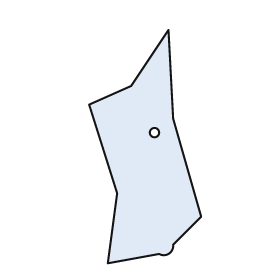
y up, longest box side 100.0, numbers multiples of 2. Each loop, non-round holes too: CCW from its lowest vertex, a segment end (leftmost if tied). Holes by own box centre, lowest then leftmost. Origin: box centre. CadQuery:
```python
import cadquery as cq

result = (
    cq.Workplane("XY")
    .moveTo(-16.0, -50.0)
    .lineTo(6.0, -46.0)
    .threePointArc((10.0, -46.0), (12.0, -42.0))
    .lineTo(24.0, -30.0)
    .lineTo(12.0, 12.0)
    .lineTo(10.0, 50.0)
    .lineTo(-6.0, 26.0)
    .lineTo(-24.0, 18.0)
    .lineTo(-12.0, -20.0)
    .close()
    .moveTo(4.0, 6.0)
    .circle(2.0)
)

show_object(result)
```